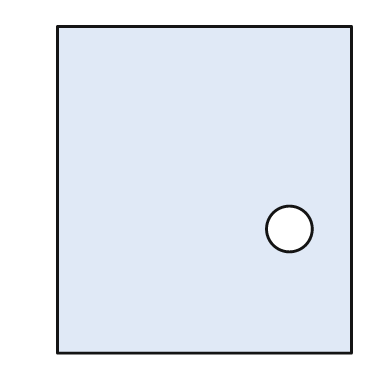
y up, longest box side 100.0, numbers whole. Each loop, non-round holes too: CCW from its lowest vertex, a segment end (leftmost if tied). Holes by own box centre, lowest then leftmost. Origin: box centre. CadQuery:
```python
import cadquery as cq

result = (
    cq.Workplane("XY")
    .moveTo(-45.0, -50.0)
    .lineTo(45.0, -50.0)
    .lineTo(45.0, 50.0)
    .lineTo(-45.0, 50.0)
    .close()
    .moveTo(26.0, -12.0)
    .circle(7.0)
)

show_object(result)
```